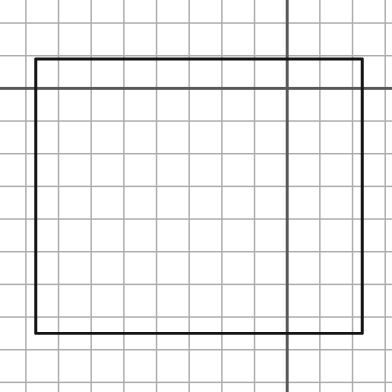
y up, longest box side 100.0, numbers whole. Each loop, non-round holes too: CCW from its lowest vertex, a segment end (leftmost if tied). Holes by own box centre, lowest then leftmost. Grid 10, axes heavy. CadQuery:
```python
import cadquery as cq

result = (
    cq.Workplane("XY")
    .moveTo(-77.0, -75.0)
    .lineTo(23.0, -75.0)
    .lineTo(23.0, 9.0)
    .lineTo(-77.0, 9.0)
    .close()
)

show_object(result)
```